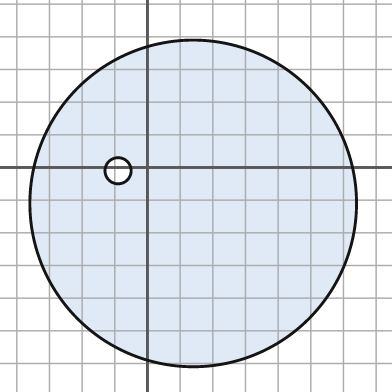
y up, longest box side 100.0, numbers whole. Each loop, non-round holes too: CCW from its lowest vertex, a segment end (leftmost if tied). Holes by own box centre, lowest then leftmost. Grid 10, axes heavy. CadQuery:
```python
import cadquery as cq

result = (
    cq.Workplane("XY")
    .moveTo(14.0, -11.0)
    .circle(50.0)
    .moveTo(-9.0, -1.0)
    .circle(4.0)
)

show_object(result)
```